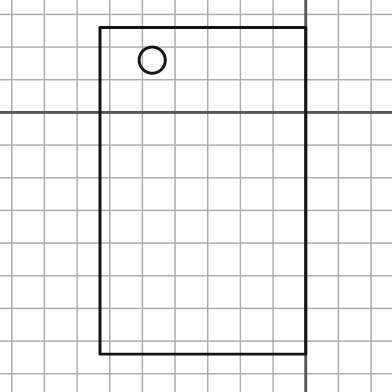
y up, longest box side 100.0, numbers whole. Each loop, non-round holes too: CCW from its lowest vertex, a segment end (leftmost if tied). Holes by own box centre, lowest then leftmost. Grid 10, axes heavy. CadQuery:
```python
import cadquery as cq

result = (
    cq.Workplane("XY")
    .moveTo(-63.0, -74.0)
    .lineTo(0.0, -74.0)
    .lineTo(0.0, 26.0)
    .lineTo(-63.0, 26.0)
    .close()
    .moveTo(-47.0, 16.0)
    .circle(4.0)
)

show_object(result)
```